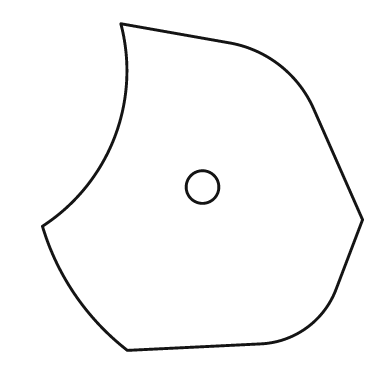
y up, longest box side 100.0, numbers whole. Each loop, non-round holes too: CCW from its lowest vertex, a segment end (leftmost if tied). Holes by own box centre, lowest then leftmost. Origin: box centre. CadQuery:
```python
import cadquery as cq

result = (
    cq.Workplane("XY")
    .moveTo(-23.0, -50.0)
    .lineTo(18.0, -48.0)
    .threePointArc((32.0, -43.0), (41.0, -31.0))
    .lineTo(49.0, -10.0)
    .lineTo(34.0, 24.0)
    .threePointArc((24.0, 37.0), (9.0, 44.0))
    .lineTo(-25.0, 50.0)
    .threePointArc((-27.0, 15.0), (-49.0, -12.0))
    .threePointArc((-39.0, -33.0), (-23.0, -50.0))
    .close()
    .moveTo(0.0, 0.0)
    .circle(5.0)
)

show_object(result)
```